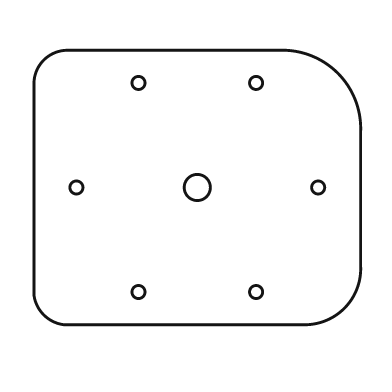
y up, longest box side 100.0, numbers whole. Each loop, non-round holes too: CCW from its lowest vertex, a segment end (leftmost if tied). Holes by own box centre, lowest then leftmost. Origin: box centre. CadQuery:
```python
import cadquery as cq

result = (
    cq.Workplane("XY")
    .moveTo(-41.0, -42.0)
    .lineTo(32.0, -42.0)
    .threePointArc((45.0, -37.0), (50.0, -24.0))
    .lineTo(50.0, 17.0)
    .threePointArc((43.0, 35.0), (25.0, 42.0))
    .lineTo(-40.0, 42.0)
    .threePointArc((-47.0, 39.0), (-50.0, 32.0))
    .lineTo(-50.0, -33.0)
    .threePointArc((-47.0, -39.0), (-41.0, -42.0))
    .close()
    .moveTo(-18.0, -32.0)
    .circle(2.0)
    .moveTo(18.0, -32.0)
    .circle(2.0)
    .moveTo(-37.0, 0.0)
    .circle(2.0)
    .moveTo(0.0, 0.0)
    .circle(4.0)
    .moveTo(37.0, 0.0)
    .circle(2.0)
    .moveTo(-18.0, 32.0)
    .circle(2.0)
    .moveTo(18.0, 32.0)
    .circle(2.0)
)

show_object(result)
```